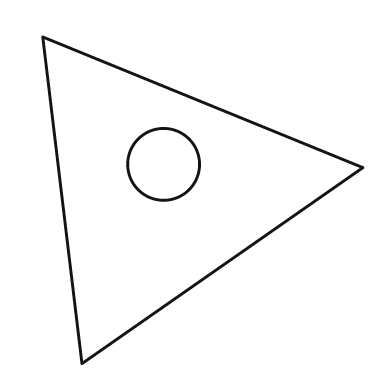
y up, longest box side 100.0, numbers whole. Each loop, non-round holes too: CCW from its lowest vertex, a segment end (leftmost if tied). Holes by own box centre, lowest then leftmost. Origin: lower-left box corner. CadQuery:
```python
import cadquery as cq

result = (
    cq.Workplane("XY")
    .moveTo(12.0, 0.0)
    .lineTo(98.0, 60.0)
    .lineTo(0.0, 100.0)
    .close()
    .moveTo(37.0, 61.0)
    .circle(11.0)
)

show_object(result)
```